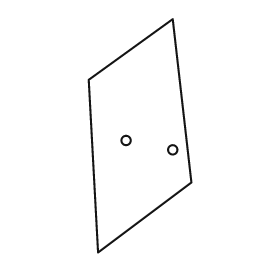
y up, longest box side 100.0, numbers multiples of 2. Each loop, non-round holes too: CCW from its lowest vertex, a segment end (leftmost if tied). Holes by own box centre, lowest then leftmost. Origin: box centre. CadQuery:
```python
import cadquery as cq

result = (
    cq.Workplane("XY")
    .moveTo(-18.0, -50.0)
    .lineTo(22.0, -20.0)
    .lineTo(14.0, 50.0)
    .lineTo(-22.0, 24.0)
    .close()
    .moveTo(14.0, -6.0)
    .circle(2.0)
    .moveTo(-6.0, -2.0)
    .circle(2.0)
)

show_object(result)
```